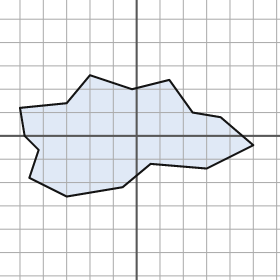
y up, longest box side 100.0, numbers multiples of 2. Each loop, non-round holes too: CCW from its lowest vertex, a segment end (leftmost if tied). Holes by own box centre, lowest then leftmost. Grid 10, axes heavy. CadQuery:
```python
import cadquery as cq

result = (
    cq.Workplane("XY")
    .moveTo(-30.0, -26.0)
    .lineTo(-6.0, -22.0)
    .lineTo(6.0, -12.0)
    .lineTo(30.0, -14.0)
    .lineTo(50.0, -4.0)
    .lineTo(36.0, 8.0)
    .lineTo(24.0, 10.0)
    .lineTo(14.0, 24.0)
    .lineTo(-2.0, 20.0)
    .lineTo(-20.0, 26.0)
    .lineTo(-30.0, 14.0)
    .lineTo(-50.0, 12.0)
    .lineTo(-48.0, 0.0)
    .lineTo(-42.0, -6.0)
    .lineTo(-46.0, -18.0)
    .close()
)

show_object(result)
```